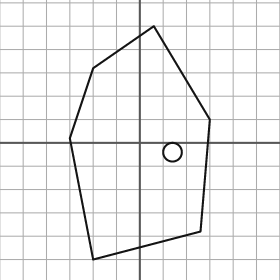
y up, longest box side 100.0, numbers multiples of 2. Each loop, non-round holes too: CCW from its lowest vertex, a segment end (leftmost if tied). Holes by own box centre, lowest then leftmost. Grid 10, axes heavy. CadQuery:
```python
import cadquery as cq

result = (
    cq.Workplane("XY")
    .moveTo(-20.0, -50.0)
    .lineTo(26.0, -38.0)
    .lineTo(30.0, 10.0)
    .lineTo(6.0, 50.0)
    .lineTo(-20.0, 32.0)
    .lineTo(-30.0, 2.0)
    .close()
    .moveTo(14.0, -4.0)
    .circle(4.0)
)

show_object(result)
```